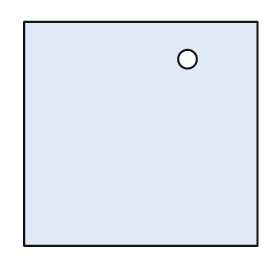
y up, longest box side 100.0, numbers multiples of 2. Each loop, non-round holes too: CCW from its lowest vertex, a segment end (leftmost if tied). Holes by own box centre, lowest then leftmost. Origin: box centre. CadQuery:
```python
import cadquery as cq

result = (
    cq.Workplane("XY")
    .moveTo(-50.0, -48.0)
    .lineTo(50.0, -48.0)
    .lineTo(50.0, 48.0)
    .lineTo(-50.0, 48.0)
    .close()
    .moveTo(20.0, 32.0)
    .circle(4.0)
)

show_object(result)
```